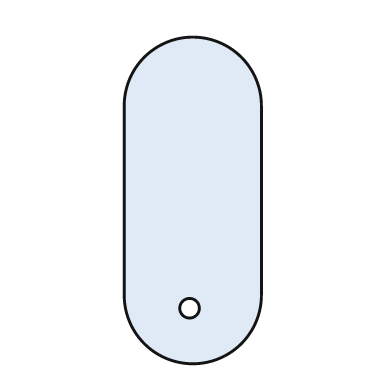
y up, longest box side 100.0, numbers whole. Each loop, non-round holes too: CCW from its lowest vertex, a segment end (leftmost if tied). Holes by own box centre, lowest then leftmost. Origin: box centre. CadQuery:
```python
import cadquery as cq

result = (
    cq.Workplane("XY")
    .moveTo(-21.0, -29.0)
    .threePointArc((0.0, -50.0), (21.0, -29.0))
    .lineTo(21.0, 29.0)
    .threePointArc((0.0, 50.0), (-21.0, 29.0))
    .close()
    .moveTo(-1.0, -33.0)
    .circle(3.0)
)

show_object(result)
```